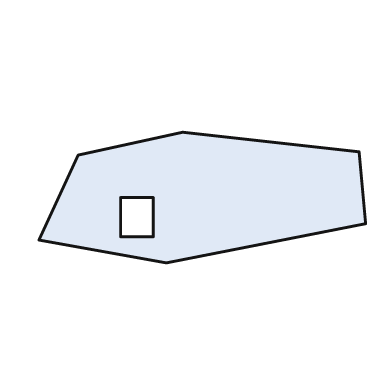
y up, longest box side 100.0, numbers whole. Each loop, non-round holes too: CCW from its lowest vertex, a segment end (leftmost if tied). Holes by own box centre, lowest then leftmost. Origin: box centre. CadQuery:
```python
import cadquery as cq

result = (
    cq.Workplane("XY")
    .moveTo(-11.0, -20.0)
    .lineTo(50.0, -8.0)
    .lineTo(48.0, 14.0)
    .lineTo(-6.0, 20.0)
    .lineTo(-38.0, 13.0)
    .lineTo(-50.0, -13.0)
    .close()
    .moveTo(-25.0, -12.0)
    .lineTo(-15.0, -12.0)
    .lineTo(-15.0, 0.0)
    .lineTo(-25.0, 0.0)
    .close()
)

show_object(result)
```